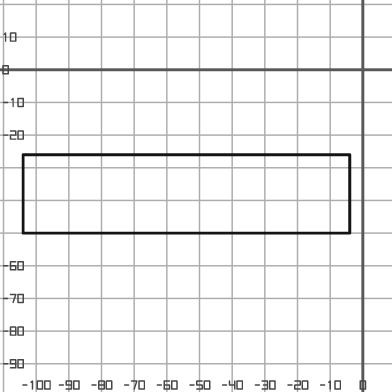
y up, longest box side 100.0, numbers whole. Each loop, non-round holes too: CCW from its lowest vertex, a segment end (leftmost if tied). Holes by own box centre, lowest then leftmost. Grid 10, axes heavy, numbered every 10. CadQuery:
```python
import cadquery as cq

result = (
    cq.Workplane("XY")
    .moveTo(-104.0, -50.0)
    .lineTo(-4.0, -50.0)
    .lineTo(-4.0, -26.0)
    .lineTo(-104.0, -26.0)
    .close()
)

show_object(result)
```